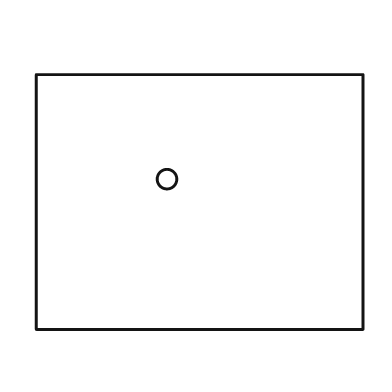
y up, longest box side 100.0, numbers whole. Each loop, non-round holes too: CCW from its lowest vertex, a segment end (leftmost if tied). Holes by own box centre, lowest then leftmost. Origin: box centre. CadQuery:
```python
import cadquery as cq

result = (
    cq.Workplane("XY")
    .moveTo(-50.0, -39.0)
    .lineTo(50.0, -39.0)
    .lineTo(50.0, 39.0)
    .lineTo(-50.0, 39.0)
    .close()
    .moveTo(-10.0, 7.0)
    .circle(3.0)
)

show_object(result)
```